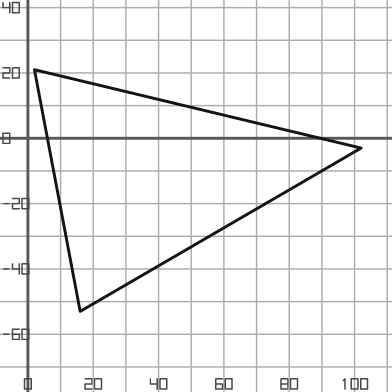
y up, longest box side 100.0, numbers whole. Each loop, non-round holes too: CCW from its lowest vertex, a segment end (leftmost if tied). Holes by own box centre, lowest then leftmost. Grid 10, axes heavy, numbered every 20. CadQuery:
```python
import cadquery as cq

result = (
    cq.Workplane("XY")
    .moveTo(16.0, -53.0)
    .lineTo(102.0, -3.0)
    .lineTo(2.0, 21.0)
    .close()
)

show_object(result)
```